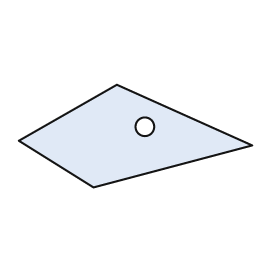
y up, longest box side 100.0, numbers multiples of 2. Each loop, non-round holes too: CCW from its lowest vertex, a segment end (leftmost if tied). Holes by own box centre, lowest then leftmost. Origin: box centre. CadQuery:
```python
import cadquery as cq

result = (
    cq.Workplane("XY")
    .moveTo(-18.0, -22.0)
    .lineTo(50.0, -4.0)
    .lineTo(-8.0, 22.0)
    .lineTo(-50.0, -2.0)
    .close()
    .moveTo(4.0, 4.0)
    .circle(4.0)
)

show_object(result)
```